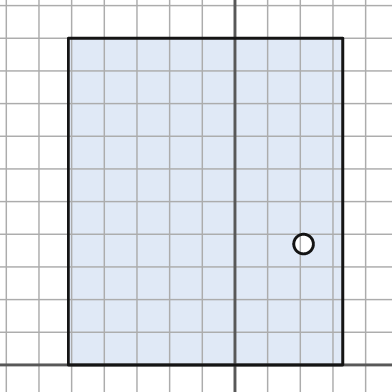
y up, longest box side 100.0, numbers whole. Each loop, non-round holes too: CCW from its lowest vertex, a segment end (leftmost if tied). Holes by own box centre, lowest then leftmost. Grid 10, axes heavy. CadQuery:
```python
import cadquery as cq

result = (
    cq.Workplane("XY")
    .moveTo(-51.0, 0.0)
    .lineTo(33.0, 0.0)
    .lineTo(33.0, 100.0)
    .lineTo(-51.0, 100.0)
    .close()
    .moveTo(21.0, 37.0)
    .circle(3.0)
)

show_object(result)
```